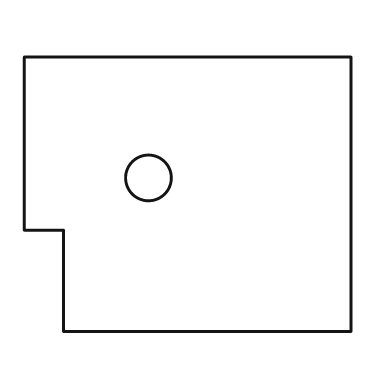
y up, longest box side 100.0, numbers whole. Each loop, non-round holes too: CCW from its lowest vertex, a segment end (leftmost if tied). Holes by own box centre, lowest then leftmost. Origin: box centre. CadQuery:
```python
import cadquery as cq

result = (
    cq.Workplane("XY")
    .moveTo(-38.0, -42.0)
    .lineTo(50.0, -42.0)
    .lineTo(50.0, 42.0)
    .lineTo(-50.0, 42.0)
    .lineTo(-50.0, -11.0)
    .lineTo(-38.0, -11.0)
    .close()
    .moveTo(-12.0, 5.0)
    .circle(7.0)
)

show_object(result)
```